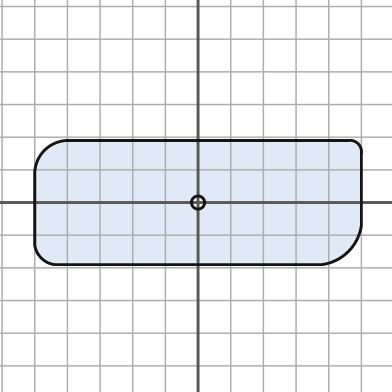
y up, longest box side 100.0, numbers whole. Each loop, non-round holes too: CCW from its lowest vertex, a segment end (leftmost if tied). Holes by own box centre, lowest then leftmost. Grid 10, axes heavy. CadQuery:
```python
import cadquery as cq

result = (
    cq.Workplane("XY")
    .moveTo(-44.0, -19.0)
    .lineTo(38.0, -19.0)
    .threePointArc((46.0, -15.0), (50.0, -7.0))
    .lineTo(50.0, 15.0)
    .threePointArc((49.0, 18.0), (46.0, 19.0))
    .lineTo(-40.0, 19.0)
    .threePointArc((-47.0, 16.0), (-50.0, 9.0))
    .lineTo(-50.0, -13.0)
    .threePointArc((-48.0, -17.0), (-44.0, -19.0))
    .close()
    .moveTo(0.0, 0.0)
    .circle(2.0)
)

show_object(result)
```